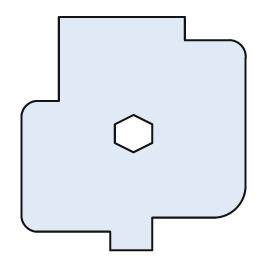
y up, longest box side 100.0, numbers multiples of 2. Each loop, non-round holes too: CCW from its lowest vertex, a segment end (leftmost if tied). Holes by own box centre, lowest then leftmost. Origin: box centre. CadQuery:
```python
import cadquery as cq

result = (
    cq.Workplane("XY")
    .moveTo(-10.0, -50.0)
    .lineTo(8.0, -50.0)
    .lineTo(8.0, -36.0)
    .lineTo(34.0, -36.0)
    .threePointArc((44.0, -32.0), (48.0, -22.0))
    .lineTo(48.0, 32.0)
    .threePointArc((46.0, 38.0), (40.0, 40.0))
    .lineTo(22.0, 40.0)
    .lineTo(22.0, 50.0)
    .lineTo(-32.0, 50.0)
    .lineTo(-32.0, 14.0)
    .lineTo(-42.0, 14.0)
    .threePointArc((-46.0, 12.0), (-48.0, 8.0))
    .lineTo(-48.0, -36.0)
    .threePointArc((-46.0, -40.0), (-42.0, -42.0))
    .lineTo(-10.0, -42.0)
    .close()
    .moveTo(0.0, -8.0)
    .lineTo(8.0, -4.0)
    .lineTo(8.0, 4.0)
    .lineTo(0.0, 8.0)
    .lineTo(-8.0, 4.0)
    .lineTo(-8.0, -4.0)
    .close()
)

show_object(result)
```